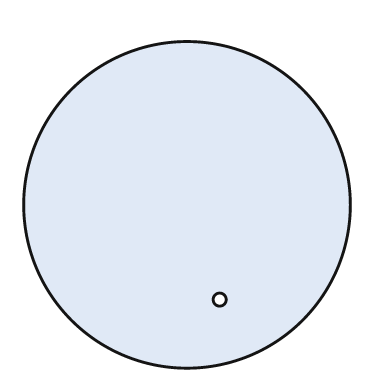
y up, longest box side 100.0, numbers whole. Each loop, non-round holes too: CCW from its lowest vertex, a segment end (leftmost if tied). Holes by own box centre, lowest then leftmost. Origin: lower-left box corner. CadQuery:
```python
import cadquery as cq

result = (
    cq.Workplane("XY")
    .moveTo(50.0, 50.0)
    .circle(50.0)
    .moveTo(60.0, 21.0)
    .circle(2.0)
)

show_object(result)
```